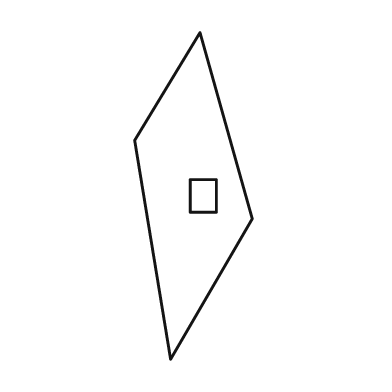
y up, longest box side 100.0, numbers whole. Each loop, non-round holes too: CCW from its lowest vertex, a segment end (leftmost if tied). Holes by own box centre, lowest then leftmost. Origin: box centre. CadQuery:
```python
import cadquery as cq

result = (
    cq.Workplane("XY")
    .moveTo(-7.0, -50.0)
    .lineTo(18.0, -7.0)
    .lineTo(2.0, 50.0)
    .lineTo(-18.0, 17.0)
    .close()
    .moveTo(-1.0, -5.0)
    .lineTo(7.0, -5.0)
    .lineTo(7.0, 5.0)
    .lineTo(-1.0, 5.0)
    .close()
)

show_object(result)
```